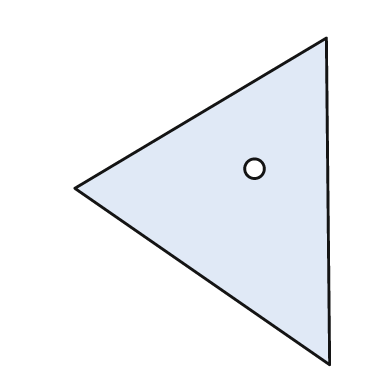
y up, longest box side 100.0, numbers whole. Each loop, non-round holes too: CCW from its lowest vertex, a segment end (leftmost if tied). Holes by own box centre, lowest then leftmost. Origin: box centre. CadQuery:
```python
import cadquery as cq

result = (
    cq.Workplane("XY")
    .moveTo(39.0, -50.0)
    .lineTo(38.0, 50.0)
    .lineTo(-39.0, 4.0)
    .close()
    .moveTo(16.0, 10.0)
    .circle(3.0)
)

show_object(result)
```